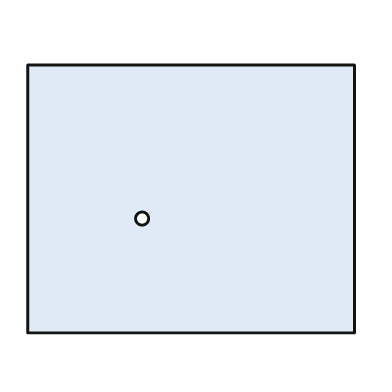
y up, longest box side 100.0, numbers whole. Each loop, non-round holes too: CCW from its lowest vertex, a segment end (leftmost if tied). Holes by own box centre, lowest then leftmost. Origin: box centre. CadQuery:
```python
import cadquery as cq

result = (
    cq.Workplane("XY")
    .moveTo(-50.0, -41.0)
    .lineTo(50.0, -41.0)
    .lineTo(50.0, 41.0)
    .lineTo(-50.0, 41.0)
    .close()
    .moveTo(-15.0, -6.0)
    .circle(2.0)
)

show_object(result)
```